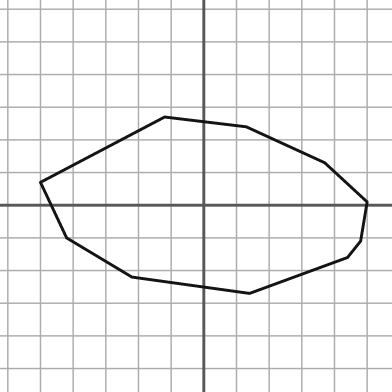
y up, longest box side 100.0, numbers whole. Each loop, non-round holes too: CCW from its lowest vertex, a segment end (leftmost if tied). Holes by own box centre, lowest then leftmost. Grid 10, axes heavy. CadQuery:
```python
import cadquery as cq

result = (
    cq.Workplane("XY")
    .moveTo(14.0, -27.0)
    .lineTo(44.0, -16.0)
    .lineTo(48.0, -11.0)
    .lineTo(50.0, 1.0)
    .lineTo(37.0, 13.0)
    .lineTo(13.0, 24.0)
    .lineTo(-12.0, 27.0)
    .lineTo(-50.0, 7.0)
    .lineTo(-42.0, -10.0)
    .lineTo(-22.0, -22.0)
    .close()
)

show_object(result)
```